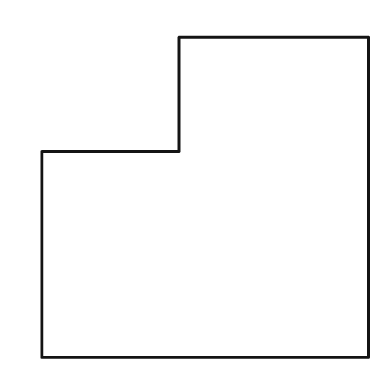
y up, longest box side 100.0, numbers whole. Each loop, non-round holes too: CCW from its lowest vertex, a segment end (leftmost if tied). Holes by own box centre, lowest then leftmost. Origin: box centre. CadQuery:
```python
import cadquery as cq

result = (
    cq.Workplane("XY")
    .moveTo(-50.0, -49.0)
    .lineTo(50.0, -49.0)
    .lineTo(50.0, 49.0)
    .lineTo(-8.0, 49.0)
    .lineTo(-8.0, 14.0)
    .lineTo(-50.0, 14.0)
    .close()
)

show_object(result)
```